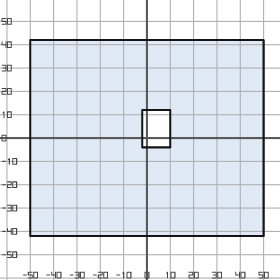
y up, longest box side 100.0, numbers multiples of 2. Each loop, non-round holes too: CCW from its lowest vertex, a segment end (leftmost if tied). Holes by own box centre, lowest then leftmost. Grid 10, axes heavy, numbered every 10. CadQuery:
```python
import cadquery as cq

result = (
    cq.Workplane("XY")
    .moveTo(-50.0, -42.0)
    .lineTo(50.0, -42.0)
    .lineTo(50.0, 42.0)
    .lineTo(-50.0, 42.0)
    .close()
    .moveTo(-2.0, -4.0)
    .lineTo(10.0, -4.0)
    .lineTo(10.0, 12.0)
    .lineTo(-2.0, 12.0)
    .close()
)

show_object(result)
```